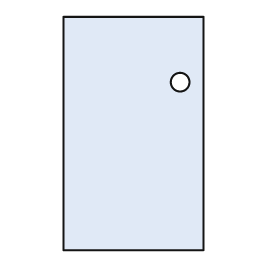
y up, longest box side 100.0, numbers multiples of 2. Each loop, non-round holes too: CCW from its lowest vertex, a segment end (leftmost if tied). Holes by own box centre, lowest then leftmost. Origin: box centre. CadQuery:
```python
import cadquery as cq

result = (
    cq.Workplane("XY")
    .moveTo(-30.0, -50.0)
    .lineTo(30.0, -50.0)
    .lineTo(30.0, 50.0)
    .lineTo(-30.0, 50.0)
    .close()
    .moveTo(20.0, 22.0)
    .circle(4.0)
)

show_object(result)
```